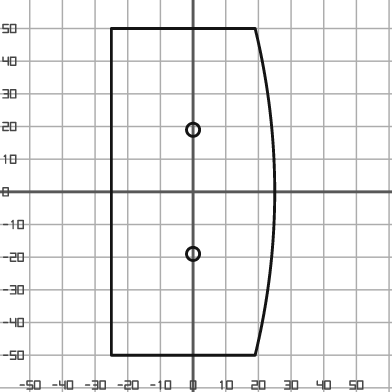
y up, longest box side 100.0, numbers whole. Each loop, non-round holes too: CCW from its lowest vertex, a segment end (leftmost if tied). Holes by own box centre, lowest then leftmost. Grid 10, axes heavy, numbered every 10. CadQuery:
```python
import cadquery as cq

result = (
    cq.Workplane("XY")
    .moveTo(-25.0, -50.0)
    .lineTo(19.0, -50.0)
    .threePointArc((25.0, 0.0), (19.0, 50.0))
    .lineTo(-25.0, 50.0)
    .close()
    .moveTo(0.0, -19.0)
    .circle(2.0)
    .moveTo(0.0, 19.0)
    .circle(2.0)
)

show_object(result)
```